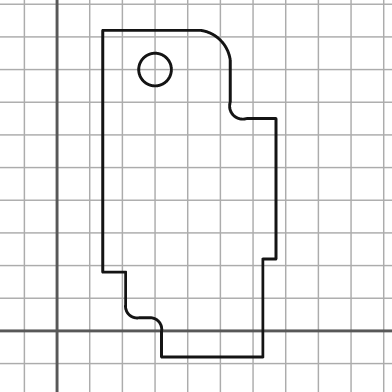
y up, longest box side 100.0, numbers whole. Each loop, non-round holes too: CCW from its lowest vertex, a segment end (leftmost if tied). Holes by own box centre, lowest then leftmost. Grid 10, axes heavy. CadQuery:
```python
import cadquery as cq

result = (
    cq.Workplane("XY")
    .moveTo(32.0, -8.0)
    .lineTo(63.0, -8.0)
    .lineTo(63.0, 22.0)
    .lineTo(67.0, 22.0)
    .lineTo(67.0, 65.0)
    .lineTo(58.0, 65.0)
    .threePointArc((54.0, 66.0), (53.0, 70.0))
    .lineTo(53.0, 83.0)
    .threePointArc((50.0, 89.0), (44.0, 92.0))
    .lineTo(14.0, 92.0)
    .lineTo(14.0, 18.0)
    .lineTo(21.0, 18.0)
    .lineTo(21.0, 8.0)
    .threePointArc((22.0, 5.0), (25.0, 4.0))
    .lineTo(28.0, 4.0)
    .threePointArc((31.0, 3.0), (32.0, 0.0))
    .close()
    .moveTo(30.0, 80.0)
    .circle(5.0)
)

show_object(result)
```